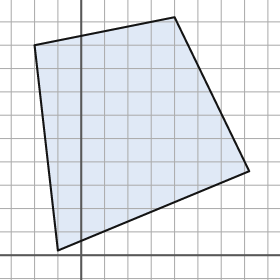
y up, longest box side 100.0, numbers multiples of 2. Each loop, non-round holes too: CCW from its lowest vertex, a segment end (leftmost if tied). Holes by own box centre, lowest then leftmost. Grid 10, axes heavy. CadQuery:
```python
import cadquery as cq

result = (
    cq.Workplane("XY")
    .moveTo(-10.0, 2.0)
    .lineTo(72.0, 36.0)
    .lineTo(40.0, 102.0)
    .lineTo(-20.0, 90.0)
    .close()
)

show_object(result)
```